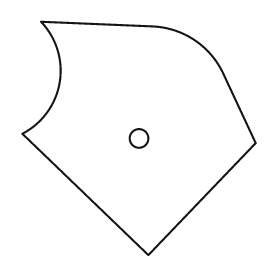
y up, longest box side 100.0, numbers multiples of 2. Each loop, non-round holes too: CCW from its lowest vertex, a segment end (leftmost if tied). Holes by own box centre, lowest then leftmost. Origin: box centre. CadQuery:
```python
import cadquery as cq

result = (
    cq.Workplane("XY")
    .moveTo(4.0, -50.0)
    .lineTo(50.0, -2.0)
    .lineTo(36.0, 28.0)
    .threePointArc((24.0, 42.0), (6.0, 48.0))
    .lineTo(-42.0, 50.0)
    .threePointArc((-34.0, 24.0), (-50.0, 2.0))
    .close()
    .moveTo(0.0, 0.0)
    .circle(4.0)
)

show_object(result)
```